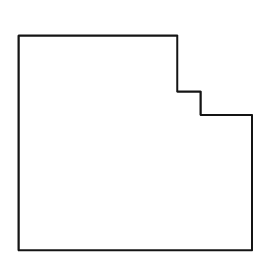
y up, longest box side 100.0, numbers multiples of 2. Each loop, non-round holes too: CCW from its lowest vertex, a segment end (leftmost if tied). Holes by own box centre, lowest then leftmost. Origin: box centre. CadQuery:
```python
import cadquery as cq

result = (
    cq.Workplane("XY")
    .moveTo(-50.0, -46.0)
    .lineTo(50.0, -46.0)
    .lineTo(50.0, 12.0)
    .lineTo(28.0, 12.0)
    .lineTo(28.0, 22.0)
    .lineTo(18.0, 22.0)
    .lineTo(18.0, 46.0)
    .lineTo(-50.0, 46.0)
    .close()
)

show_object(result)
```